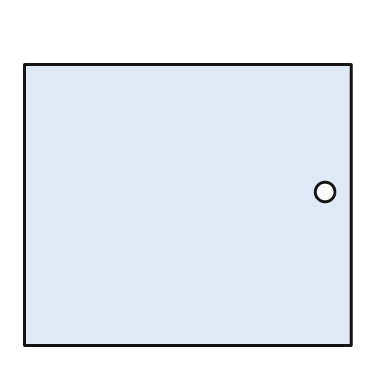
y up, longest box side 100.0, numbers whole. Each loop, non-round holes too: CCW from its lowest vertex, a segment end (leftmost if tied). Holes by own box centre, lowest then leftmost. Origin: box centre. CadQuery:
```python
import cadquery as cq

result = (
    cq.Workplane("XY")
    .moveTo(-50.0, -43.0)
    .lineTo(50.0, -43.0)
    .lineTo(50.0, 43.0)
    .lineTo(-50.0, 43.0)
    .close()
    .moveTo(42.0, 4.0)
    .circle(3.0)
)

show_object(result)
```